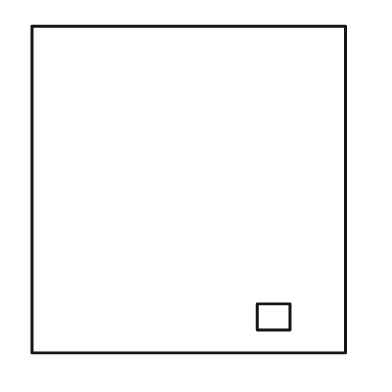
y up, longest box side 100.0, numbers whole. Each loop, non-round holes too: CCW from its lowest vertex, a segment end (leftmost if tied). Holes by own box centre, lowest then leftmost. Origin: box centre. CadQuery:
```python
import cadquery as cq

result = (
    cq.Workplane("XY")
    .moveTo(-48.0, -50.0)
    .lineTo(48.0, -50.0)
    .lineTo(48.0, 50.0)
    .lineTo(-48.0, 50.0)
    .close()
    .moveTo(21.0, -43.0)
    .lineTo(31.0, -43.0)
    .lineTo(31.0, -35.0)
    .lineTo(21.0, -35.0)
    .close()
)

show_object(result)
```